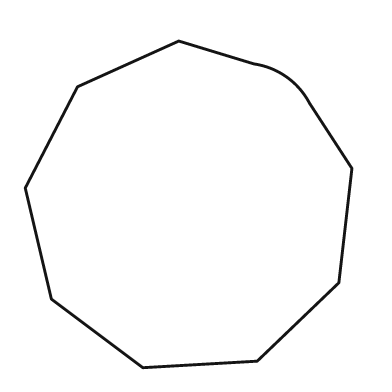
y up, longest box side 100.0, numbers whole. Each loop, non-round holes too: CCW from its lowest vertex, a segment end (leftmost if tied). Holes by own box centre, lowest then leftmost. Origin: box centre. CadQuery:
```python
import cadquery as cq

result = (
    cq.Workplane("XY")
    .moveTo(-14.0, -50.0)
    .lineTo(21.0, -48.0)
    .lineTo(46.0, -24.0)
    .lineTo(50.0, 11.0)
    .lineTo(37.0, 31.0)
    .threePointArc((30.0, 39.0), (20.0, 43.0))
    .lineTo(-3.0, 50.0)
    .lineTo(-34.0, 36.0)
    .lineTo(-50.0, 5.0)
    .lineTo(-42.0, -29.0)
    .close()
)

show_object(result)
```